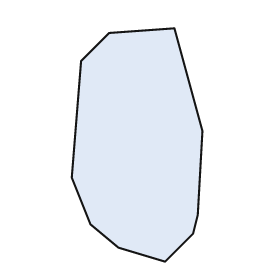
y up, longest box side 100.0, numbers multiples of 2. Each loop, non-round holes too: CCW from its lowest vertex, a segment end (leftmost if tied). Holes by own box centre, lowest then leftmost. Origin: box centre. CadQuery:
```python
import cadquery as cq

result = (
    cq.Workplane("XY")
    .moveTo(12.0, -50.0)
    .lineTo(24.0, -38.0)
    .lineTo(26.0, -30.0)
    .lineTo(28.0, 6.0)
    .lineTo(16.0, 50.0)
    .lineTo(-12.0, 48.0)
    .lineTo(-24.0, 36.0)
    .lineTo(-28.0, -14.0)
    .lineTo(-20.0, -34.0)
    .lineTo(-8.0, -44.0)
    .close()
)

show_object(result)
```